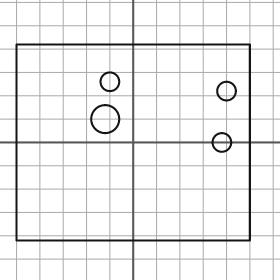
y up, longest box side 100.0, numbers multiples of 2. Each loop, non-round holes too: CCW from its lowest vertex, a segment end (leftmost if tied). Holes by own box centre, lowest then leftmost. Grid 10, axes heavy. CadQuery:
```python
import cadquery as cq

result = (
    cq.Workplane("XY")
    .moveTo(-50.0, -42.0)
    .lineTo(50.0, -42.0)
    .lineTo(50.0, 42.0)
    .lineTo(-50.0, 42.0)
    .close()
    .moveTo(38.0, 0.0)
    .circle(4.0)
    .moveTo(-12.0, 10.0)
    .circle(6.0)
    .moveTo(40.0, 22.0)
    .circle(4.0)
    .moveTo(-10.0, 26.0)
    .circle(4.0)
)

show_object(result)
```